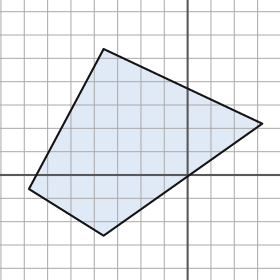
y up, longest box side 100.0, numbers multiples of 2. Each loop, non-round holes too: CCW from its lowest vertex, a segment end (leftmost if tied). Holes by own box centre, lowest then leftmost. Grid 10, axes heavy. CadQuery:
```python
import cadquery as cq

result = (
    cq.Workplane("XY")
    .moveTo(-36.0, -26.0)
    .lineTo(32.0, 22.0)
    .lineTo(-36.0, 54.0)
    .lineTo(-68.0, -6.0)
    .close()
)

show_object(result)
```